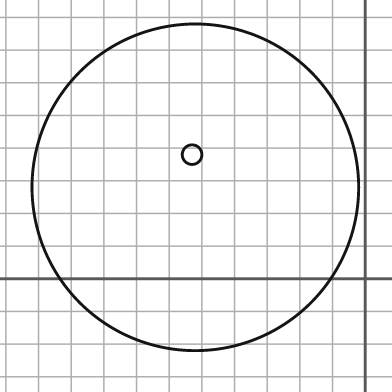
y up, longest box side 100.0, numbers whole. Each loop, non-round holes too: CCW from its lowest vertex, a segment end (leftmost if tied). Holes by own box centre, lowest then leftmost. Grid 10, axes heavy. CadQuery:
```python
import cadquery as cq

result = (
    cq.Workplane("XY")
    .moveTo(-52.0, 28.0)
    .circle(50.0)
    .moveTo(-53.0, 38.0)
    .circle(3.0)
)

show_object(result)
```